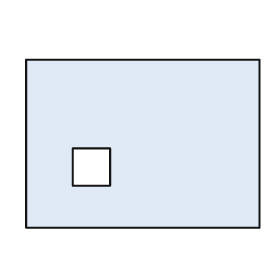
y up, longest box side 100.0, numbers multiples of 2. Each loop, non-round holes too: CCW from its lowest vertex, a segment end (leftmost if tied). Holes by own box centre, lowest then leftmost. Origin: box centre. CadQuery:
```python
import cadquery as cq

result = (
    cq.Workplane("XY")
    .moveTo(-50.0, -36.0)
    .lineTo(50.0, -36.0)
    .lineTo(50.0, 36.0)
    .lineTo(-50.0, 36.0)
    .close()
    .moveTo(-30.0, -18.0)
    .lineTo(-14.0, -18.0)
    .lineTo(-14.0, -2.0)
    .lineTo(-30.0, -2.0)
    .close()
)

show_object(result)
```